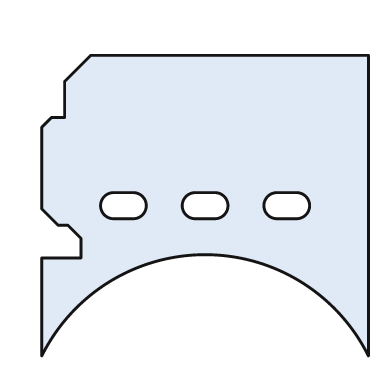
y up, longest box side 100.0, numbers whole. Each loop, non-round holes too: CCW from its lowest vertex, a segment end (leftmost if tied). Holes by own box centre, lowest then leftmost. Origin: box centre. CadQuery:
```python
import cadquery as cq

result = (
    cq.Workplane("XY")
    .moveTo(-50.0, -46.0)
    .threePointArc((0.0, -15.0), (50.0, -46.0))
    .lineTo(50.0, 46.0)
    .lineTo(-35.0, 46.0)
    .lineTo(-43.0, 38.0)
    .lineTo(-43.0, 27.0)
    .lineTo(-47.0, 27.0)
    .lineTo(-50.0, 24.0)
    .lineTo(-50.0, -1.0)
    .lineTo(-45.0, -6.0)
    .lineTo(-42.0, -6.0)
    .lineTo(-38.0, -10.0)
    .lineTo(-38.0, -16.0)
    .lineTo(-50.0, -16.0)
    .close()
    .moveTo(-28.0, -4.0)
    .lineTo(-22.0, -4.0)
    .threePointArc((-18.0, 0.0), (-22.0, 4.0))
    .lineTo(-28.0, 4.0)
    .threePointArc((-32.0, 0.0), (-28.0, -4.0))
    .close()
    .moveTo(-3.0, -4.0)
    .lineTo(3.0, -4.0)
    .threePointArc((7.0, 0.0), (3.0, 4.0))
    .lineTo(-3.0, 4.0)
    .threePointArc((-7.0, 0.0), (-3.0, -4.0))
    .close()
    .moveTo(22.0, -4.0)
    .lineTo(28.0, -4.0)
    .threePointArc((32.0, 0.0), (28.0, 4.0))
    .lineTo(22.0, 4.0)
    .threePointArc((18.0, 0.0), (22.0, -4.0))
    .close()
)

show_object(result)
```